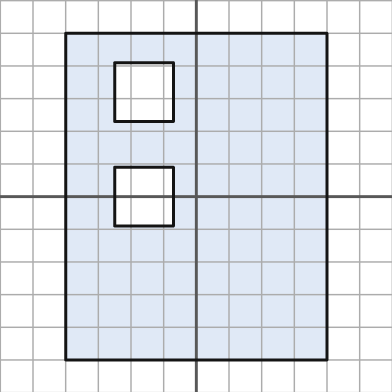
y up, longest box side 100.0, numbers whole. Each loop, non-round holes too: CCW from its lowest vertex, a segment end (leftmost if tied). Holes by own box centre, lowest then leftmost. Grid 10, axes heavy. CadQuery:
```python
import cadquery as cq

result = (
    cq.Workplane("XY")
    .moveTo(-40.0, -50.0)
    .lineTo(40.0, -50.0)
    .lineTo(40.0, 50.0)
    .lineTo(-40.0, 50.0)
    .close()
    .moveTo(-25.0, -9.0)
    .lineTo(-7.0, -9.0)
    .lineTo(-7.0, 9.0)
    .lineTo(-25.0, 9.0)
    .close()
    .moveTo(-25.0, 23.0)
    .lineTo(-7.0, 23.0)
    .lineTo(-7.0, 41.0)
    .lineTo(-25.0, 41.0)
    .close()
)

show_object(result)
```